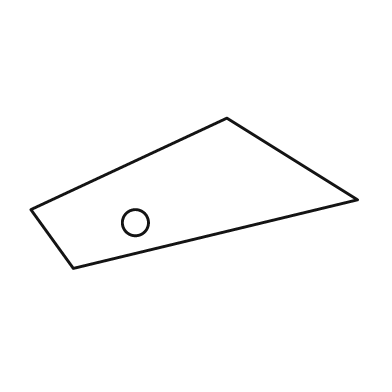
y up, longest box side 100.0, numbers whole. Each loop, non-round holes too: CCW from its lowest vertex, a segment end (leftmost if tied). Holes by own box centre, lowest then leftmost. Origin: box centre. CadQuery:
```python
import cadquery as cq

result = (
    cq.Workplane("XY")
    .moveTo(-37.0, -23.0)
    .lineTo(50.0, -2.0)
    .lineTo(10.0, 23.0)
    .lineTo(-50.0, -5.0)
    .close()
    .moveTo(-18.0, -9.0)
    .circle(4.0)
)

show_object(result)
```